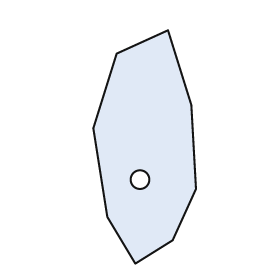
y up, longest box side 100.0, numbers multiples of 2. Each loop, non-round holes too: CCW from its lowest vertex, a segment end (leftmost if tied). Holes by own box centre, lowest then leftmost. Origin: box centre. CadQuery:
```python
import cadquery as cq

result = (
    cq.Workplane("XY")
    .moveTo(-4.0, -50.0)
    .lineTo(12.0, -40.0)
    .lineTo(22.0, -18.0)
    .lineTo(20.0, 18.0)
    .lineTo(10.0, 50.0)
    .lineTo(-12.0, 40.0)
    .lineTo(-22.0, 8.0)
    .lineTo(-16.0, -30.0)
    .close()
    .moveTo(-2.0, -14.0)
    .circle(4.0)
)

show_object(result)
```